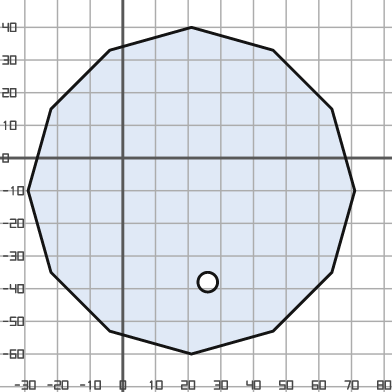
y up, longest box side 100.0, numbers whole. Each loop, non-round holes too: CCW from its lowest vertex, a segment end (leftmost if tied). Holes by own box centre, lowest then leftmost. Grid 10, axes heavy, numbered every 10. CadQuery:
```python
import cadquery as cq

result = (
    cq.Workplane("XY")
    .moveTo(21.0, -60.0)
    .lineTo(46.0, -53.0)
    .lineTo(64.0, -35.0)
    .lineTo(71.0, -10.0)
    .lineTo(64.0, 15.0)
    .lineTo(46.0, 33.0)
    .lineTo(21.0, 40.0)
    .lineTo(-4.0, 33.0)
    .lineTo(-22.0, 15.0)
    .lineTo(-29.0, -10.0)
    .lineTo(-22.0, -35.0)
    .lineTo(-4.0, -53.0)
    .close()
    .moveTo(26.0, -38.0)
    .circle(3.0)
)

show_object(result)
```